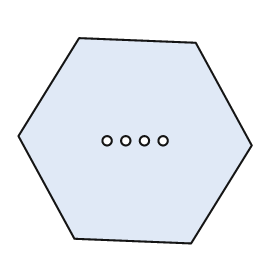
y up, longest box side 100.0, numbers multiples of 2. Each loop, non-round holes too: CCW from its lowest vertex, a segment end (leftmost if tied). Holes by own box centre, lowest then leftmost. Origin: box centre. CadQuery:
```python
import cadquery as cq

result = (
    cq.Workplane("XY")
    .moveTo(24.0, -44.0)
    .lineTo(50.0, -2.0)
    .lineTo(26.0, 42.0)
    .lineTo(-24.0, 44.0)
    .lineTo(-50.0, 2.0)
    .lineTo(-26.0, -42.0)
    .close()
    .moveTo(-12.0, 0.0)
    .circle(2.0)
    .moveTo(-4.0, 0.0)
    .circle(2.0)
    .moveTo(4.0, 0.0)
    .circle(2.0)
    .moveTo(12.0, 0.0)
    .circle(2.0)
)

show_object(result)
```